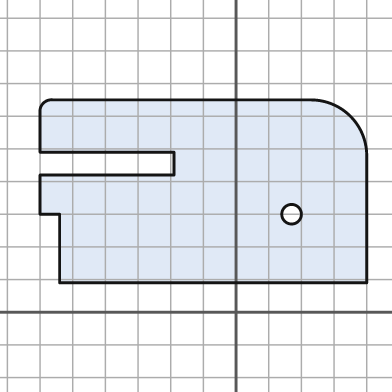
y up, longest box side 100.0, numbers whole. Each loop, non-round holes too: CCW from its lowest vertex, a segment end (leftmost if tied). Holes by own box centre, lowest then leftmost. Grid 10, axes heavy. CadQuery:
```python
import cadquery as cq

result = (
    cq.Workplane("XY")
    .moveTo(-54.0, 9.0)
    .lineTo(40.0, 9.0)
    .lineTo(40.0, 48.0)
    .threePointArc((35.0, 60.0), (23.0, 65.0))
    .lineTo(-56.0, 65.0)
    .threePointArc((-59.0, 64.0), (-60.0, 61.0))
    .lineTo(-60.0, 49.0)
    .lineTo(-19.0, 49.0)
    .lineTo(-19.0, 42.0)
    .lineTo(-60.0, 42.0)
    .lineTo(-60.0, 30.0)
    .lineTo(-54.0, 30.0)
    .close()
    .moveTo(17.0, 30.0)
    .circle(3.0)
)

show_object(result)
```